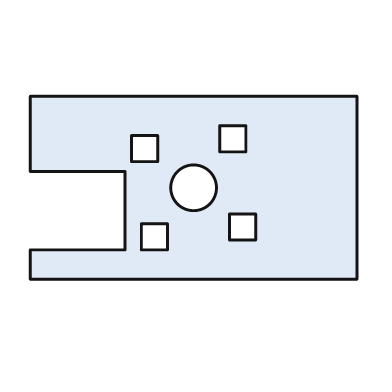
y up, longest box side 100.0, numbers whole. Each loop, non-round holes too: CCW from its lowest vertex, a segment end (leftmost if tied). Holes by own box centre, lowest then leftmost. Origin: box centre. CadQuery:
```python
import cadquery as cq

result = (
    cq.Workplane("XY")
    .moveTo(-50.0, -28.0)
    .lineTo(50.0, -28.0)
    .lineTo(50.0, 28.0)
    .lineTo(-50.0, 28.0)
    .lineTo(-50.0, 5.0)
    .lineTo(-21.0, 5.0)
    .lineTo(-21.0, -19.0)
    .lineTo(-50.0, -19.0)
    .close()
    .moveTo(-16.0, -19.0)
    .lineTo(-8.0, -19.0)
    .lineTo(-8.0, -11.0)
    .lineTo(-16.0, -11.0)
    .close()
    .moveTo(11.0, -16.0)
    .lineTo(19.0, -16.0)
    .lineTo(19.0, -8.0)
    .lineTo(11.0, -8.0)
    .close()
    .moveTo(0.0, 0.0)
    .circle(7.0)
    .moveTo(-19.0, 8.0)
    .lineTo(-11.0, 8.0)
    .lineTo(-11.0, 16.0)
    .lineTo(-19.0, 16.0)
    .close()
    .moveTo(8.0, 11.0)
    .lineTo(16.0, 11.0)
    .lineTo(16.0, 19.0)
    .lineTo(8.0, 19.0)
    .close()
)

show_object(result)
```